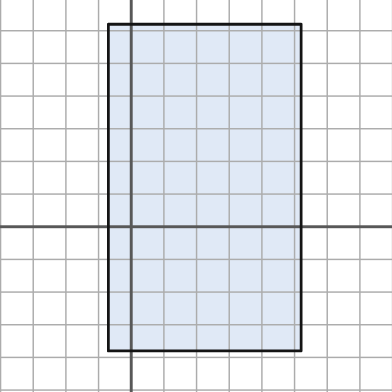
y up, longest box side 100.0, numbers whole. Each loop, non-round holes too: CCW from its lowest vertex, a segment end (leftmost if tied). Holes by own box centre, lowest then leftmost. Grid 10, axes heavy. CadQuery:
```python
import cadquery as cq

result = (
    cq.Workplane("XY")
    .moveTo(-7.0, -38.0)
    .lineTo(52.0, -38.0)
    .lineTo(52.0, 62.0)
    .lineTo(-7.0, 62.0)
    .close()
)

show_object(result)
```